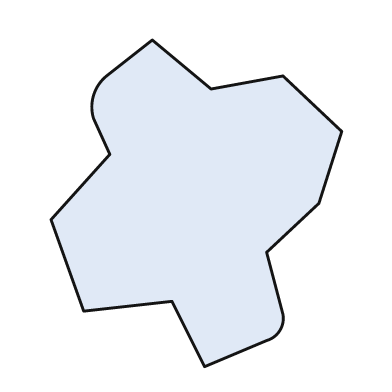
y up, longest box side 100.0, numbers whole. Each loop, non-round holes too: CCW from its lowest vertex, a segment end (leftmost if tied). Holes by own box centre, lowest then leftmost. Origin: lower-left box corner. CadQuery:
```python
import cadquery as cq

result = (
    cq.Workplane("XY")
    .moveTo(47.0, 0.0)
    .lineTo(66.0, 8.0)
    .threePointArc((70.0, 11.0), (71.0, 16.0))
    .lineTo(66.0, 35.0)
    .lineTo(82.0, 50.0)
    .lineTo(89.0, 72.0)
    .lineTo(71.0, 89.0)
    .lineTo(49.0, 85.0)
    .lineTo(31.0, 100.0)
    .lineTo(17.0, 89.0)
    .threePointArc((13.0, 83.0), (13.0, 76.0))
    .lineTo(18.0, 65.0)
    .lineTo(0.0, 45.0)
    .lineTo(10.0, 17.0)
    .lineTo(37.0, 20.0)
    .close()
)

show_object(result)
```